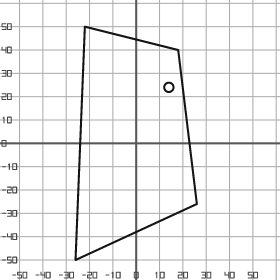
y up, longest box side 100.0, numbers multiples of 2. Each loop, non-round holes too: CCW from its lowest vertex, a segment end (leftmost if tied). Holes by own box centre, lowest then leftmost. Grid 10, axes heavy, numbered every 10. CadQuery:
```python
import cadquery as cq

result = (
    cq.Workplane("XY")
    .moveTo(-26.0, -50.0)
    .lineTo(26.0, -26.0)
    .lineTo(18.0, 40.0)
    .lineTo(-22.0, 50.0)
    .close()
    .moveTo(14.0, 24.0)
    .circle(2.0)
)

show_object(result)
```